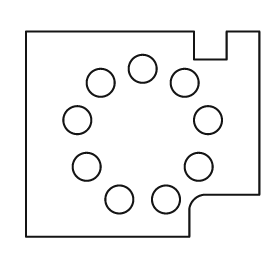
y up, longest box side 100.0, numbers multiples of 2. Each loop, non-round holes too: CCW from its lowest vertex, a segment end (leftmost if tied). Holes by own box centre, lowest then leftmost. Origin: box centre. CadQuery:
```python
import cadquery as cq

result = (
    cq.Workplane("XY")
    .moveTo(-50.0, -44.0)
    .lineTo(20.0, -44.0)
    .lineTo(20.0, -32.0)
    .threePointArc((22.0, -28.0), (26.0, -26.0))
    .lineTo(50.0, -26.0)
    .lineTo(50.0, 44.0)
    .lineTo(36.0, 44.0)
    .lineTo(36.0, 32.0)
    .lineTo(22.0, 32.0)
    .lineTo(22.0, 44.0)
    .lineTo(-50.0, 44.0)
    .close()
    .moveTo(-10.0, -28.0)
    .circle(6.0)
    .moveTo(10.0, -28.0)
    .circle(6.0)
    .moveTo(-24.0, -14.0)
    .circle(6.0)
    .moveTo(24.0, -14.0)
    .circle(6.0)
    .moveTo(-28.0, 6.0)
    .circle(6.0)
    .moveTo(28.0, 6.0)
    .circle(6.0)
    .moveTo(-18.0, 22.0)
    .circle(6.0)
    .moveTo(18.0, 22.0)
    .circle(6.0)
    .moveTo(0.0, 28.0)
    .circle(6.0)
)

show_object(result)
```